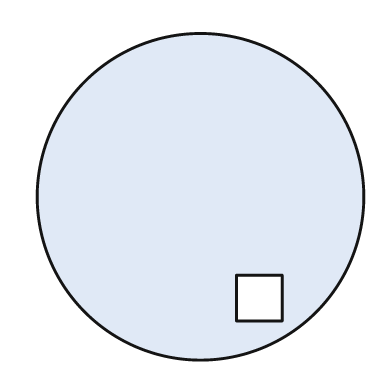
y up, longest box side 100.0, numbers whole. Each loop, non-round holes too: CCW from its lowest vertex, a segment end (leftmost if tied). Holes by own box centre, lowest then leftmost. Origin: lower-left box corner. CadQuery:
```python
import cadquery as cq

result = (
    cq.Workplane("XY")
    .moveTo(50.0, 50.0)
    .circle(50.0)
    .moveTo(61.0, 12.0)
    .lineTo(75.0, 12.0)
    .lineTo(75.0, 26.0)
    .lineTo(61.0, 26.0)
    .close()
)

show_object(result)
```